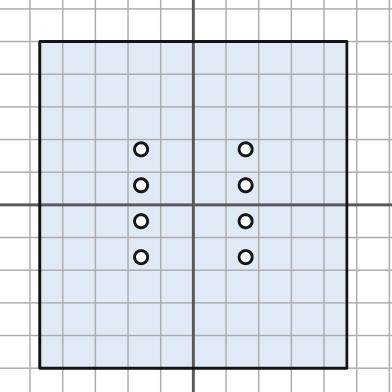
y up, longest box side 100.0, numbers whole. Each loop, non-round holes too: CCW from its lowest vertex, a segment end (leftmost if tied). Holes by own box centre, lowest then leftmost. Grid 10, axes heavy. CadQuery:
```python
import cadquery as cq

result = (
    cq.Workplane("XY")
    .moveTo(-47.0, -50.0)
    .lineTo(47.0, -50.0)
    .lineTo(47.0, 50.0)
    .lineTo(-47.0, 50.0)
    .close()
    .moveTo(-16.0, -16.0)
    .circle(2.0)
    .moveTo(16.0, -16.0)
    .circle(2.0)
    .moveTo(-16.0, -5.0)
    .circle(2.0)
    .moveTo(16.0, -5.0)
    .circle(2.0)
    .moveTo(-16.0, 6.0)
    .circle(2.0)
    .moveTo(16.0, 6.0)
    .circle(2.0)
    .moveTo(-16.0, 17.0)
    .circle(2.0)
    .moveTo(16.0, 17.0)
    .circle(2.0)
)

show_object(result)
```